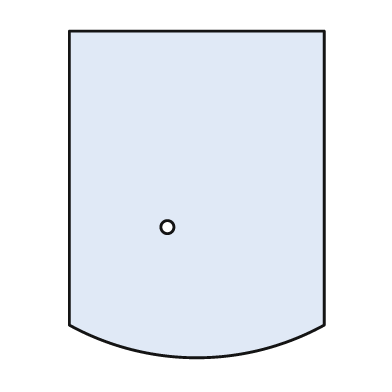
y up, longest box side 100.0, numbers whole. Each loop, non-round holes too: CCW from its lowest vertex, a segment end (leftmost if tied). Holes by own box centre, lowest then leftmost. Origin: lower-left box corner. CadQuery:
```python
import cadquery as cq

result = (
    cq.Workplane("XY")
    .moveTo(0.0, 10.0)
    .threePointArc((39.0, 0.0), (78.0, 10.0))
    .lineTo(78.0, 100.0)
    .lineTo(0.0, 100.0)
    .close()
    .moveTo(30.0, 40.0)
    .circle(2.0)
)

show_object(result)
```